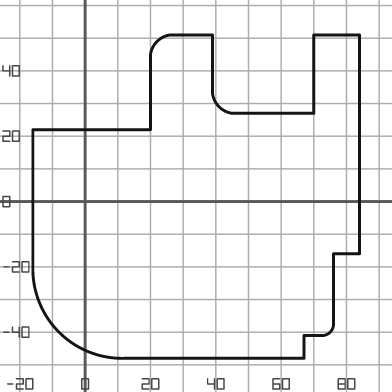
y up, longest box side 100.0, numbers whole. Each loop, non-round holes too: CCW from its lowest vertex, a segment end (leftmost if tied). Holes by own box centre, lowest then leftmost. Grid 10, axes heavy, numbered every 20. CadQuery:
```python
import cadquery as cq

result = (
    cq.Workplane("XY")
    .moveTo(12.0, -48.0)
    .lineTo(67.0, -48.0)
    .lineTo(67.0, -41.0)
    .lineTo(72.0, -41.0)
    .threePointArc((75.0, -40.0), (76.0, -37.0))
    .lineTo(76.0, -16.0)
    .lineTo(84.0, -16.0)
    .lineTo(84.0, 51.0)
    .lineTo(70.0, 51.0)
    .lineTo(70.0, 27.0)
    .lineTo(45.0, 27.0)
    .threePointArc((41.0, 29.0), (39.0, 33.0))
    .lineTo(39.0, 51.0)
    .lineTo(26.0, 51.0)
    .threePointArc((22.0, 49.0), (20.0, 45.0))
    .lineTo(20.0, 22.0)
    .lineTo(-16.0, 22.0)
    .lineTo(-16.0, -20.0)
    .threePointArc((-8.0, -40.0), (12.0, -48.0))
    .close()
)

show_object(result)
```